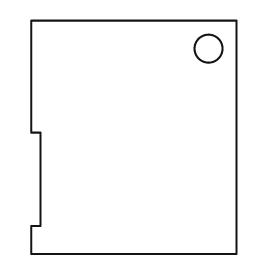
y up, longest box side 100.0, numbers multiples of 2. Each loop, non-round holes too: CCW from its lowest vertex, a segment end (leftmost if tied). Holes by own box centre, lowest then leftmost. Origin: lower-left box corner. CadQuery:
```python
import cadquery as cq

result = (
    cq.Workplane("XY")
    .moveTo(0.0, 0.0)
    .lineTo(88.0, 0.0)
    .lineTo(88.0, 100.0)
    .lineTo(0.0, 100.0)
    .lineTo(0.0, 52.0)
    .lineTo(4.0, 52.0)
    .lineTo(4.0, 12.0)
    .lineTo(0.0, 12.0)
    .close()
    .moveTo(76.0, 88.0)
    .circle(6.0)
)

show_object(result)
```